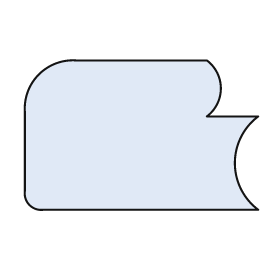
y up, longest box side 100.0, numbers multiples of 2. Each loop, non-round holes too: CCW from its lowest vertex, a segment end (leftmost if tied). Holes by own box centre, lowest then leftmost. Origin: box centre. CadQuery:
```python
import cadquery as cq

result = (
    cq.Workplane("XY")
    .moveTo(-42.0, -32.0)
    .lineTo(50.0, -32.0)
    .threePointArc((40.0, -12.0), (50.0, 8.0))
    .lineTo(28.0, 8.0)
    .threePointArc((34.0, 20.0), (28.0, 32.0))
    .lineTo(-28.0, 32.0)
    .threePointArc((-44.0, 26.0), (-50.0, 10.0))
    .lineTo(-50.0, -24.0)
    .threePointArc((-48.0, -30.0), (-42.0, -32.0))
    .close()
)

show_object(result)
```